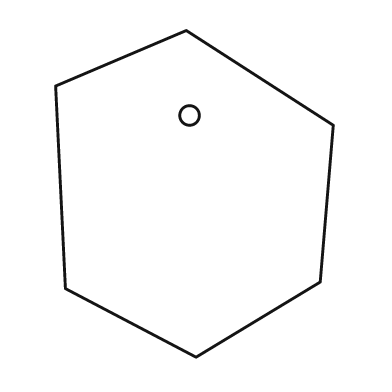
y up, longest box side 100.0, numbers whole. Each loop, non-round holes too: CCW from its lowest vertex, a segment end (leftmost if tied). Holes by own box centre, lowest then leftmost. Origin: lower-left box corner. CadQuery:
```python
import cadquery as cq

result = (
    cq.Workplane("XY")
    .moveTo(43.0, 0.0)
    .lineTo(81.0, 23.0)
    .lineTo(85.0, 71.0)
    .lineTo(40.0, 100.0)
    .lineTo(0.0, 83.0)
    .lineTo(3.0, 21.0)
    .close()
    .moveTo(41.0, 74.0)
    .circle(3.0)
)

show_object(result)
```